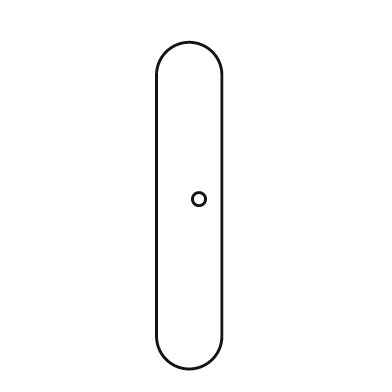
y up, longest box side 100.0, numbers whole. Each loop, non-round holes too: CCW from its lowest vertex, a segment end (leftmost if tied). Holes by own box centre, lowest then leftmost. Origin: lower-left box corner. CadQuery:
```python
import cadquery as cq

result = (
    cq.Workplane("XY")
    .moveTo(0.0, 10.0)
    .threePointArc((10.0, 0.0), (20.0, 10.0))
    .lineTo(20.0, 90.0)
    .threePointArc((10.0, 100.0), (0.0, 90.0))
    .close()
    .moveTo(13.0, 52.0)
    .circle(2.0)
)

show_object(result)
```